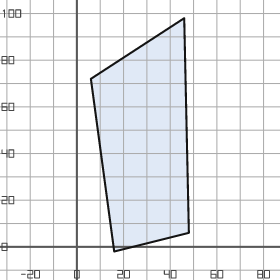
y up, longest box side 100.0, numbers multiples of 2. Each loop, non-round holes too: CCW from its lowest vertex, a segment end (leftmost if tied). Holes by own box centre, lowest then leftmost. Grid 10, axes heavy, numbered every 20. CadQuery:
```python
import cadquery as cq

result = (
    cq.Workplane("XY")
    .moveTo(16.0, -2.0)
    .lineTo(48.0, 6.0)
    .lineTo(46.0, 98.0)
    .lineTo(6.0, 72.0)
    .close()
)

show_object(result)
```